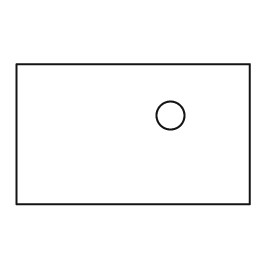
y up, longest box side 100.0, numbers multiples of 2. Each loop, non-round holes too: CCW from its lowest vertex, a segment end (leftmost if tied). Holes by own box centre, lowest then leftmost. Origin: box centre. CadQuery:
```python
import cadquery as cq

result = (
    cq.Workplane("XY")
    .moveTo(-50.0, -30.0)
    .lineTo(50.0, -30.0)
    .lineTo(50.0, 30.0)
    .lineTo(-50.0, 30.0)
    .close()
    .moveTo(16.0, 8.0)
    .circle(6.0)
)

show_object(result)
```